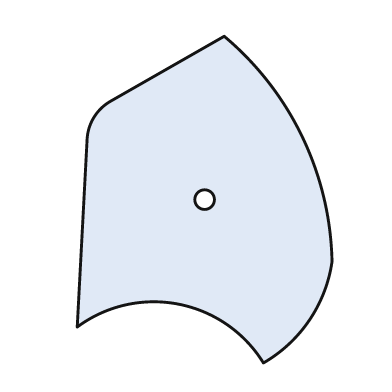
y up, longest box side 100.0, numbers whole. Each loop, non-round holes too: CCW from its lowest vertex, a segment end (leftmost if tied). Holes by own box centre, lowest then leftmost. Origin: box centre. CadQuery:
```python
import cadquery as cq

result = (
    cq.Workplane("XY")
    .moveTo(18.0, -50.0)
    .threePointArc((32.0, -37.0), (39.0, -19.0))
    .threePointArc((30.0, 19.0), (6.0, 50.0))
    .lineTo(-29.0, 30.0)
    .threePointArc((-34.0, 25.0), (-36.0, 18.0))
    .lineTo(-39.0, -39.0)
    .threePointArc((-8.0, -32.0), (18.0, -50.0))
    .close()
    .moveTo(0.0, 0.0)
    .circle(3.0)
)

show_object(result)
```